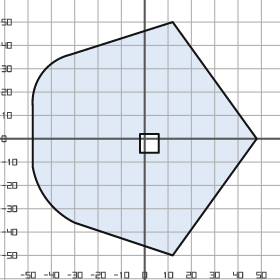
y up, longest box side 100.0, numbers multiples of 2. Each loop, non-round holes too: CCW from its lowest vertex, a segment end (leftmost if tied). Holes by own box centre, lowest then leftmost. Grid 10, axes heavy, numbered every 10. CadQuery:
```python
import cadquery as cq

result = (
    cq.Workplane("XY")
    .moveTo(12.0, -50.0)
    .lineTo(48.0, 0.0)
    .lineTo(12.0, 50.0)
    .lineTo(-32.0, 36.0)
    .threePointArc((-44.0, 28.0), (-48.0, 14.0))
    .lineTo(-48.0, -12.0)
    .threePointArc((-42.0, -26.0), (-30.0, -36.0))
    .close()
    .moveTo(-2.0, -6.0)
    .lineTo(6.0, -6.0)
    .lineTo(6.0, 2.0)
    .lineTo(-2.0, 2.0)
    .close()
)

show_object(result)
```